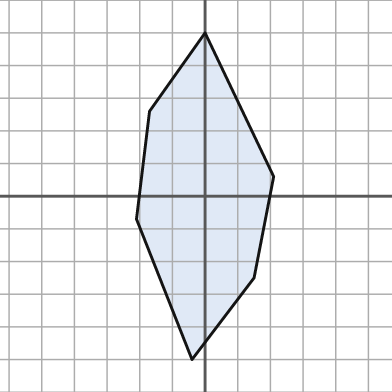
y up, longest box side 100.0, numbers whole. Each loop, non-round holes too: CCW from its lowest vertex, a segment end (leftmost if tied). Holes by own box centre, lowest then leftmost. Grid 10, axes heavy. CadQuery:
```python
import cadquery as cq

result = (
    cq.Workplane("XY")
    .moveTo(-4.0, -50.0)
    .lineTo(15.0, -25.0)
    .lineTo(21.0, 6.0)
    .lineTo(0.0, 50.0)
    .lineTo(-17.0, 26.0)
    .lineTo(-21.0, -7.0)
    .close()
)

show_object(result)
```